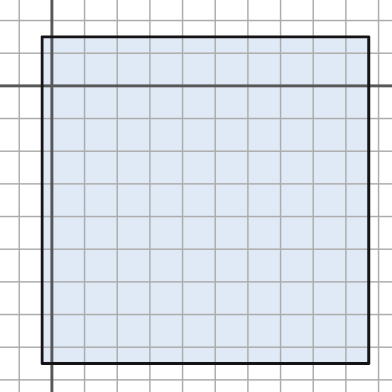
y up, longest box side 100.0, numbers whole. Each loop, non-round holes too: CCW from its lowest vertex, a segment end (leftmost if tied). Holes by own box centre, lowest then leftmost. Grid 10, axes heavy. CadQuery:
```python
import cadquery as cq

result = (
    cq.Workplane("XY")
    .moveTo(-3.0, -85.0)
    .lineTo(97.0, -85.0)
    .lineTo(97.0, 15.0)
    .lineTo(-3.0, 15.0)
    .close()
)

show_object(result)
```